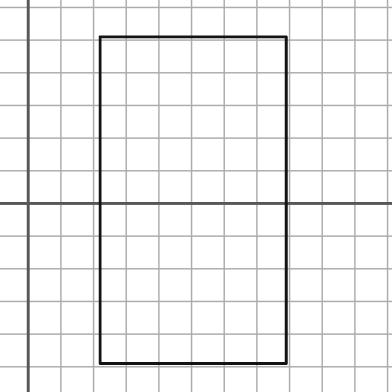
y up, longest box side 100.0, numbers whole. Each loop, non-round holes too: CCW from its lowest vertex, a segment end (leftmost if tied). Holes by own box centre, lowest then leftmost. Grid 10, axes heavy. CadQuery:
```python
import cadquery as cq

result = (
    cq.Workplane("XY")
    .moveTo(22.0, -49.0)
    .lineTo(79.0, -49.0)
    .lineTo(79.0, 51.0)
    .lineTo(22.0, 51.0)
    .close()
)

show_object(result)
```